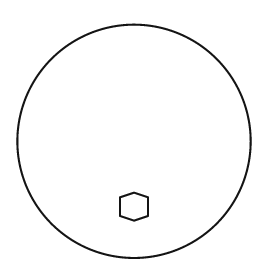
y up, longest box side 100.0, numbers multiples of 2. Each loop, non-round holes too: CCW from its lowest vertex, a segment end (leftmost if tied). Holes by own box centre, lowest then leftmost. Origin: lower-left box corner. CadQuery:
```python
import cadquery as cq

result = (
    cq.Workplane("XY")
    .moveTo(50.0, 50.0)
    .circle(50.0)
    .moveTo(50.0, 16.0)
    .lineTo(56.0, 18.0)
    .lineTo(56.0, 26.0)
    .lineTo(50.0, 28.0)
    .lineTo(44.0, 26.0)
    .lineTo(44.0, 18.0)
    .close()
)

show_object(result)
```